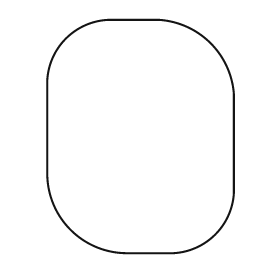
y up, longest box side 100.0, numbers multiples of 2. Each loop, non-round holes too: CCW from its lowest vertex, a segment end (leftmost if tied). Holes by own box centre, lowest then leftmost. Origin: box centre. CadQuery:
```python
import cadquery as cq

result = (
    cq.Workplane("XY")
    .moveTo(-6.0, -50.0)
    .lineTo(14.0, -50.0)
    .threePointArc((32.0, -42.0), (40.0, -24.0))
    .lineTo(40.0, 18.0)
    .threePointArc((30.0, 40.0), (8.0, 50.0))
    .lineTo(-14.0, 50.0)
    .threePointArc((-32.0, 42.0), (-40.0, 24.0))
    .lineTo(-40.0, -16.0)
    .threePointArc((-30.0, -40.0), (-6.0, -50.0))
    .close()
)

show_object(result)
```